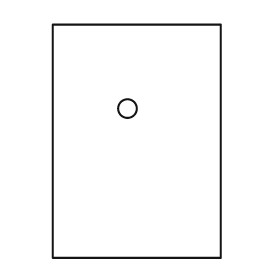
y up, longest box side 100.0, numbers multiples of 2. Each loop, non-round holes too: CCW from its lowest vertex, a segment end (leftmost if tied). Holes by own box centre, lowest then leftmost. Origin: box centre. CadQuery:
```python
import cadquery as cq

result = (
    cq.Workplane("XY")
    .moveTo(-36.0, -50.0)
    .lineTo(36.0, -50.0)
    .lineTo(36.0, 50.0)
    .lineTo(-36.0, 50.0)
    .close()
    .moveTo(-4.0, 14.0)
    .circle(4.0)
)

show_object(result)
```